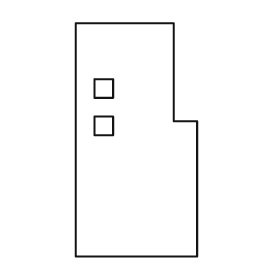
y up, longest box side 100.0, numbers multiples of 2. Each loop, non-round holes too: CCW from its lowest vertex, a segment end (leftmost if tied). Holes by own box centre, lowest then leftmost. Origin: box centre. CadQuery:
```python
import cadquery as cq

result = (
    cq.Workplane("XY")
    .moveTo(-26.0, -50.0)
    .lineTo(26.0, -50.0)
    .lineTo(26.0, 8.0)
    .lineTo(16.0, 8.0)
    .lineTo(16.0, 50.0)
    .lineTo(-26.0, 50.0)
    .close()
    .moveTo(-18.0, 2.0)
    .lineTo(-10.0, 2.0)
    .lineTo(-10.0, 10.0)
    .lineTo(-18.0, 10.0)
    .close()
    .moveTo(-18.0, 18.0)
    .lineTo(-10.0, 18.0)
    .lineTo(-10.0, 26.0)
    .lineTo(-18.0, 26.0)
    .close()
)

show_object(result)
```